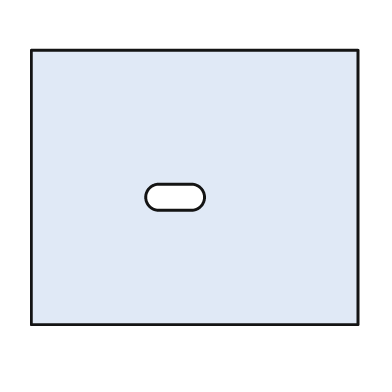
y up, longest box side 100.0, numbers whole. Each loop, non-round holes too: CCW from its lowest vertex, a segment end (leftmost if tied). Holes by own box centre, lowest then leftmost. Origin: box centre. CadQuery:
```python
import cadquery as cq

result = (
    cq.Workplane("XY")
    .moveTo(-50.0, -42.0)
    .lineTo(50.0, -42.0)
    .lineTo(50.0, 42.0)
    .lineTo(-50.0, 42.0)
    .close()
    .moveTo(-11.0, -7.0)
    .lineTo(-1.0, -7.0)
    .threePointArc((3.0, -3.0), (-1.0, 1.0))
    .lineTo(-11.0, 1.0)
    .threePointArc((-15.0, -3.0), (-11.0, -7.0))
    .close()
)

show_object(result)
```